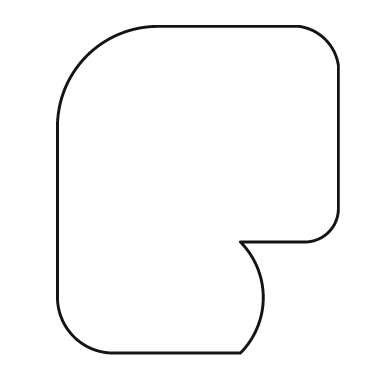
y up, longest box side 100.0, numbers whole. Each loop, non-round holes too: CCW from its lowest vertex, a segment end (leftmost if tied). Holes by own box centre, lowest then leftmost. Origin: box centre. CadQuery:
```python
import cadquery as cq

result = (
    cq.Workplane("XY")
    .moveTo(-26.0, -50.0)
    .lineTo(13.0, -50.0)
    .threePointArc((20.0, -33.0), (13.0, -16.0))
    .lineTo(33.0, -16.0)
    .threePointArc((40.0, -13.0), (43.0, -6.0))
    .lineTo(43.0, 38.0)
    .threePointArc((39.0, 46.0), (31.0, 50.0))
    .lineTo(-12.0, 50.0)
    .threePointArc((-34.0, 41.0), (-43.0, 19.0))
    .lineTo(-43.0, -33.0)
    .threePointArc((-38.0, -45.0), (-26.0, -50.0))
    .close()
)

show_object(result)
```